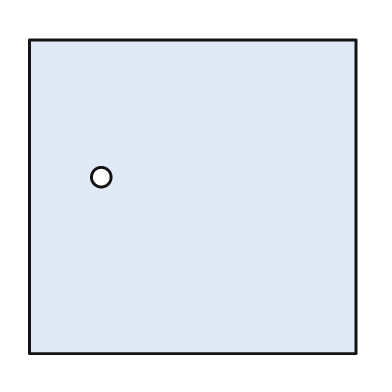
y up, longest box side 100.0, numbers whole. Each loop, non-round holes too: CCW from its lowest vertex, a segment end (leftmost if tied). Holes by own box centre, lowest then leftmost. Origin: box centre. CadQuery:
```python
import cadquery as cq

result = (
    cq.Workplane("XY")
    .moveTo(-50.0, -48.0)
    .lineTo(50.0, -48.0)
    .lineTo(50.0, 48.0)
    .lineTo(-50.0, 48.0)
    .close()
    .moveTo(-28.0, 6.0)
    .circle(3.0)
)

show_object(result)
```